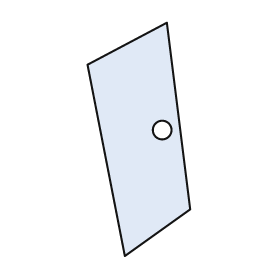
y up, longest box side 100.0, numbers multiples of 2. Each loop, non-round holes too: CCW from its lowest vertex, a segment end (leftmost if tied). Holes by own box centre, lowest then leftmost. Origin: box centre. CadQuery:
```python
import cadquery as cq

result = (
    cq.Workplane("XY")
    .moveTo(-6.0, -50.0)
    .lineTo(22.0, -30.0)
    .lineTo(12.0, 50.0)
    .lineTo(-22.0, 32.0)
    .close()
    .moveTo(10.0, 4.0)
    .circle(4.0)
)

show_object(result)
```